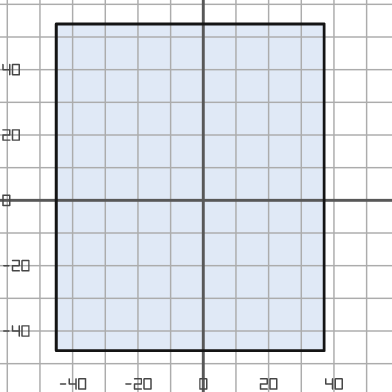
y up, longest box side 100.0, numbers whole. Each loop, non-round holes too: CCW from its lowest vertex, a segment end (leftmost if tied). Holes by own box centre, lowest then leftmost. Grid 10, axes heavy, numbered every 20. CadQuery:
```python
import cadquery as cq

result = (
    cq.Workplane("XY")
    .moveTo(-45.0, -46.0)
    .lineTo(37.0, -46.0)
    .lineTo(37.0, 54.0)
    .lineTo(-45.0, 54.0)
    .close()
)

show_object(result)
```